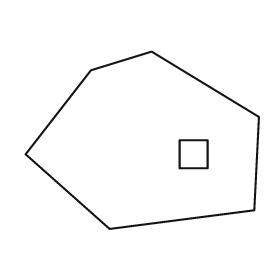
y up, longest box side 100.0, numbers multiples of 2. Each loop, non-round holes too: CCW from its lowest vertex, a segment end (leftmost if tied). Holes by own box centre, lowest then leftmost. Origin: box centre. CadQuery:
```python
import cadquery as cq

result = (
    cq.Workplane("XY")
    .moveTo(-14.0, -38.0)
    .lineTo(48.0, -30.0)
    .lineTo(50.0, 10.0)
    .lineTo(4.0, 38.0)
    .lineTo(-22.0, 30.0)
    .lineTo(-50.0, -6.0)
    .close()
    .moveTo(16.0, -12.0)
    .lineTo(28.0, -12.0)
    .lineTo(28.0, 0.0)
    .lineTo(16.0, 0.0)
    .close()
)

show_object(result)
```